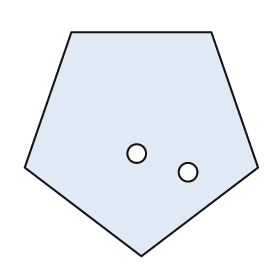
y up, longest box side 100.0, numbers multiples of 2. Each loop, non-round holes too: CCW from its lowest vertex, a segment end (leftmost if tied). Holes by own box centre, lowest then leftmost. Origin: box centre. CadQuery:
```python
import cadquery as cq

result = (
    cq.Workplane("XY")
    .moveTo(0.0, -48.0)
    .lineTo(50.0, -10.0)
    .lineTo(30.0, 48.0)
    .lineTo(-30.0, 48.0)
    .lineTo(-50.0, -10.0)
    .close()
    .moveTo(20.0, -12.0)
    .circle(4.0)
    .moveTo(-2.0, -4.0)
    .circle(4.0)
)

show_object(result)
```